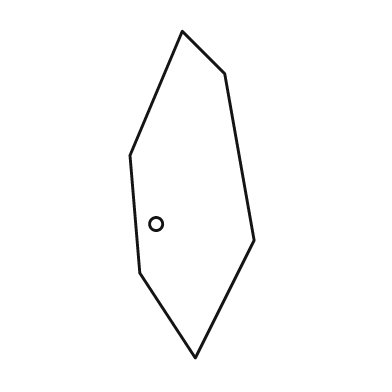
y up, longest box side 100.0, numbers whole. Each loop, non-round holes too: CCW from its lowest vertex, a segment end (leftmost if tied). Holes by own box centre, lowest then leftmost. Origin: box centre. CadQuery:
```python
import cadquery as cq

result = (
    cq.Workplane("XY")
    .moveTo(1.0, -50.0)
    .lineTo(19.0, -14.0)
    .lineTo(10.0, 37.0)
    .lineTo(-3.0, 50.0)
    .lineTo(-19.0, 12.0)
    .lineTo(-16.0, -24.0)
    .close()
    .moveTo(-11.0, -9.0)
    .circle(2.0)
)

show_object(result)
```